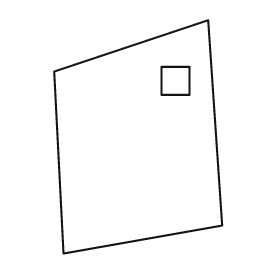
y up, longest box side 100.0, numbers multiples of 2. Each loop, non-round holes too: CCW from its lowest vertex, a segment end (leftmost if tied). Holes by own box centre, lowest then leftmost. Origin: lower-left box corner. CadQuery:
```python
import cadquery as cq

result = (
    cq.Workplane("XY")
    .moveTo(4.0, 0.0)
    .lineTo(72.0, 12.0)
    .lineTo(66.0, 100.0)
    .lineTo(0.0, 78.0)
    .close()
    .moveTo(46.0, 68.0)
    .lineTo(58.0, 68.0)
    .lineTo(58.0, 80.0)
    .lineTo(46.0, 80.0)
    .close()
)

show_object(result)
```